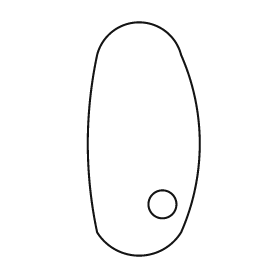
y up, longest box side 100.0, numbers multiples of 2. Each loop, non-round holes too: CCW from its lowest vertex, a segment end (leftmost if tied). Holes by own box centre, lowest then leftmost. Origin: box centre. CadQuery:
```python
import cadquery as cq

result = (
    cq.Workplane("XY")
    .moveTo(-20.0, -40.0)
    .threePointArc((-2.0, -50.0), (16.0, -40.0))
    .threePointArc((24.0, -2.0), (16.0, 36.0))
    .threePointArc((-2.0, 50.0), (-20.0, 36.0))
    .threePointArc((-24.0, -2.0), (-20.0, -40.0))
    .close()
    .moveTo(8.0, -28.0)
    .circle(6.0)
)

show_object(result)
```